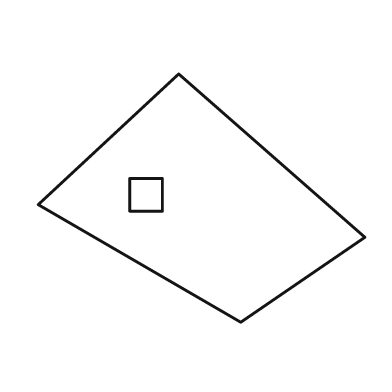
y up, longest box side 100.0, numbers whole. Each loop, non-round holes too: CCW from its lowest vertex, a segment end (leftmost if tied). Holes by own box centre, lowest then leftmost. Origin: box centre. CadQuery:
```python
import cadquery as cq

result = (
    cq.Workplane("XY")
    .moveTo(12.0, -38.0)
    .lineTo(50.0, -12.0)
    .lineTo(-7.0, 38.0)
    .lineTo(-50.0, -2.0)
    .close()
    .moveTo(-22.0, -4.0)
    .lineTo(-12.0, -4.0)
    .lineTo(-12.0, 6.0)
    .lineTo(-22.0, 6.0)
    .close()
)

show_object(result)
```